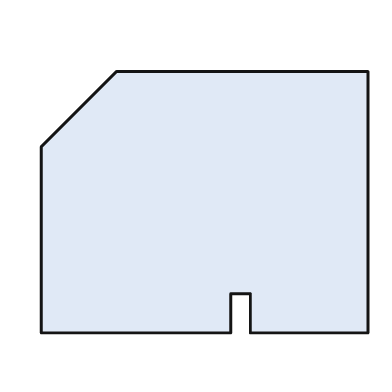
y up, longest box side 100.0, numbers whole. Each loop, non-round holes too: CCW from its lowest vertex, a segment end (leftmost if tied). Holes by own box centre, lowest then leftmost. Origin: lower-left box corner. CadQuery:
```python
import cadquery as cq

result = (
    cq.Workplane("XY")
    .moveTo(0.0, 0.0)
    .lineTo(58.0, 0.0)
    .lineTo(58.0, 12.0)
    .lineTo(64.0, 12.0)
    .lineTo(64.0, 0.0)
    .lineTo(100.0, 0.0)
    .lineTo(100.0, 80.0)
    .lineTo(23.0, 80.0)
    .lineTo(0.0, 57.0)
    .close()
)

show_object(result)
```